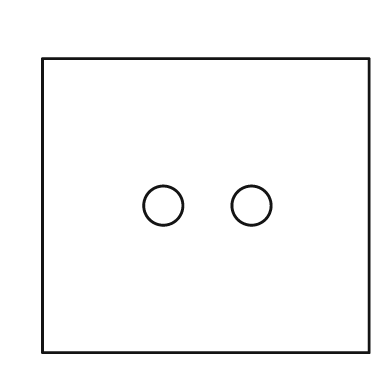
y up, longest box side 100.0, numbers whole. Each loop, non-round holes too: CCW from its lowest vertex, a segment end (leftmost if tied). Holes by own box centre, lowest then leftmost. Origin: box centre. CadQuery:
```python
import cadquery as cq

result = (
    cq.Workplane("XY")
    .moveTo(-50.0, -45.0)
    .lineTo(50.0, -45.0)
    .lineTo(50.0, 45.0)
    .lineTo(-50.0, 45.0)
    .close()
    .moveTo(-13.0, 0.0)
    .circle(6.0)
    .moveTo(14.0, 0.0)
    .circle(6.0)
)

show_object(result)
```